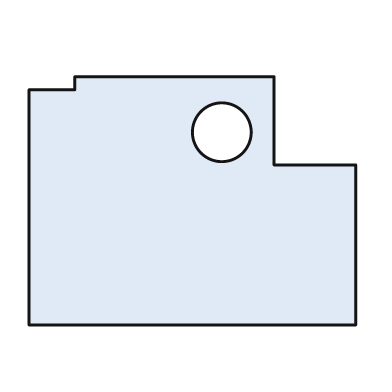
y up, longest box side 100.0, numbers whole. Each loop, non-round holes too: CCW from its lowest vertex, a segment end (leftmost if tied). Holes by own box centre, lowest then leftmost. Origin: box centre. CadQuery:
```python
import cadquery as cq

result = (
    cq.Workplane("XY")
    .moveTo(-50.0, -38.0)
    .lineTo(50.0, -38.0)
    .lineTo(50.0, 11.0)
    .lineTo(25.0, 11.0)
    .lineTo(25.0, 38.0)
    .lineTo(-36.0, 38.0)
    .lineTo(-36.0, 34.0)
    .lineTo(-50.0, 34.0)
    .close()
    .moveTo(9.0, 21.0)
    .circle(9.0)
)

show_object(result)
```